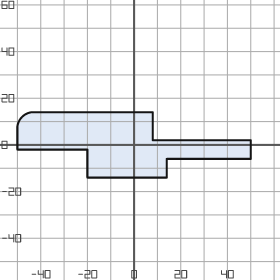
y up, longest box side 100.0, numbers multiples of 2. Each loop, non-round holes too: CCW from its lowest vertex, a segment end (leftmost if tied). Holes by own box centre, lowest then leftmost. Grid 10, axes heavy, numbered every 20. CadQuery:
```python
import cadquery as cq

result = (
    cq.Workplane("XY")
    .moveTo(-20.0, -14.0)
    .lineTo(14.0, -14.0)
    .lineTo(14.0, -6.0)
    .lineTo(50.0, -6.0)
    .lineTo(50.0, 2.0)
    .lineTo(8.0, 2.0)
    .lineTo(8.0, 14.0)
    .lineTo(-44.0, 14.0)
    .threePointArc((-48.0, 12.0), (-50.0, 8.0))
    .lineTo(-50.0, -2.0)
    .lineTo(-20.0, -2.0)
    .close()
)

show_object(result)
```